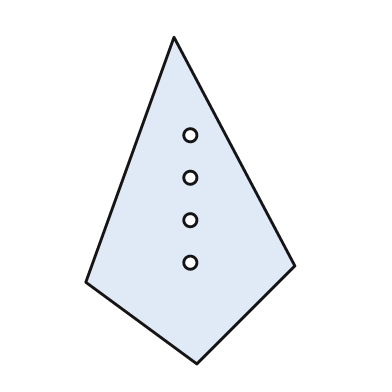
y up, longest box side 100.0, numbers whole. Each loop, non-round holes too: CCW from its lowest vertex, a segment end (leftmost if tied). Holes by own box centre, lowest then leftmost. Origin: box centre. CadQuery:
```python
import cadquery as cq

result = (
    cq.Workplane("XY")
    .moveTo(2.0, -50.0)
    .lineTo(32.0, -20.0)
    .lineTo(-5.0, 50.0)
    .lineTo(-32.0, -25.0)
    .close()
    .moveTo(0.0, -19.0)
    .circle(2.0)
    .moveTo(0.0, -6.0)
    .circle(2.0)
    .moveTo(0.0, 7.0)
    .circle(2.0)
    .moveTo(0.0, 20.0)
    .circle(2.0)
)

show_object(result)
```